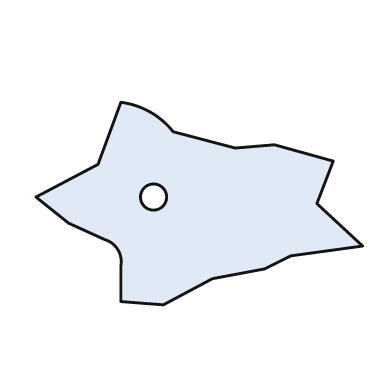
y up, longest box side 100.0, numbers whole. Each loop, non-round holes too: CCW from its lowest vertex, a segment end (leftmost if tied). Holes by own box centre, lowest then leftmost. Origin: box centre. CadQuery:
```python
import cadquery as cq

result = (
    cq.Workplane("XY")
    .moveTo(-11.0, -31.0)
    .lineTo(4.0, -23.0)
    .lineTo(20.0, -20.0)
    .lineTo(28.0, -16.0)
    .lineTo(50.0, -13.0)
    .lineTo(36.0, 0.0)
    .lineTo(41.0, 13.0)
    .lineTo(23.0, 18.0)
    .lineTo(11.0, 17.0)
    .lineTo(-8.0, 22.0)
    .threePointArc((-15.0, 28.0), (-24.0, 31.0))
    .lineTo(-31.0, 12.0)
    .lineTo(-50.0, 2.0)
    .lineTo(-40.0, -6.0)
    .lineTo(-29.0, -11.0)
    .threePointArc((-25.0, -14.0), (-24.0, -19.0))
    .lineTo(-24.0, -30.0)
    .close()
    .moveTo(-14.0, 2.0)
    .circle(4.0)
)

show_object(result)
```